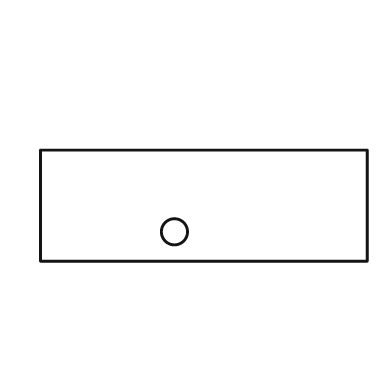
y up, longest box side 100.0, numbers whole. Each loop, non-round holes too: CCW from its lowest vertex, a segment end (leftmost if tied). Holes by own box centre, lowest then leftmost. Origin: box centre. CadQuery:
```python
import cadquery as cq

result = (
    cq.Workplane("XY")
    .moveTo(-50.0, -17.0)
    .lineTo(50.0, -17.0)
    .lineTo(50.0, 17.0)
    .lineTo(-50.0, 17.0)
    .close()
    .moveTo(-9.0, -8.0)
    .circle(4.0)
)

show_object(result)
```